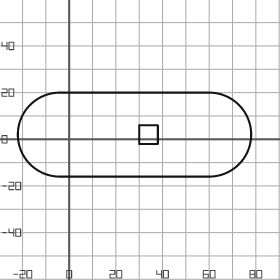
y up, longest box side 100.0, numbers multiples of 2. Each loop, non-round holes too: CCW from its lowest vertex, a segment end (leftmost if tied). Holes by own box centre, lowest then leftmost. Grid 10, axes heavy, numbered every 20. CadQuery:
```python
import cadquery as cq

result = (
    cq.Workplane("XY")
    .moveTo(-4.0, -16.0)
    .lineTo(60.0, -16.0)
    .threePointArc((78.0, 2.0), (60.0, 20.0))
    .lineTo(-4.0, 20.0)
    .threePointArc((-22.0, 2.0), (-4.0, -16.0))
    .close()
    .moveTo(30.0, -2.0)
    .lineTo(38.0, -2.0)
    .lineTo(38.0, 6.0)
    .lineTo(30.0, 6.0)
    .close()
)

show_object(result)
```